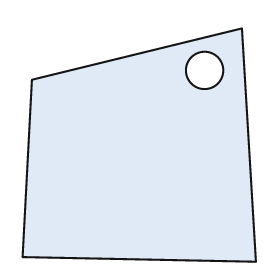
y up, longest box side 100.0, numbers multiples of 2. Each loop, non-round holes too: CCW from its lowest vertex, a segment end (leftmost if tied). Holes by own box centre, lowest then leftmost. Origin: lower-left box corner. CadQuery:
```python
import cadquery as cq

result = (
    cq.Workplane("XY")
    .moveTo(100.0, 0.0)
    .lineTo(94.0, 100.0)
    .lineTo(4.0, 78.0)
    .lineTo(0.0, 2.0)
    .close()
    .moveTo(78.0, 82.0)
    .circle(8.0)
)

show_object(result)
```